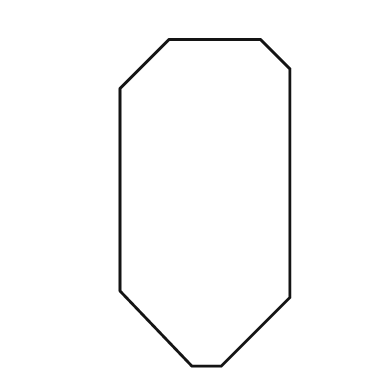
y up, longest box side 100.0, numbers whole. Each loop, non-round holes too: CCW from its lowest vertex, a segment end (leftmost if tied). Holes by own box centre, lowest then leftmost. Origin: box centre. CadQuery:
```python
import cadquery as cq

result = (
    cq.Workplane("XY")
    .moveTo(-4.0, -50.0)
    .lineTo(5.0, -50.0)
    .lineTo(26.0, -29.0)
    .lineTo(26.0, 41.0)
    .lineTo(17.0, 50.0)
    .lineTo(-11.0, 50.0)
    .lineTo(-26.0, 35.0)
    .lineTo(-26.0, -27.0)
    .close()
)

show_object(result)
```